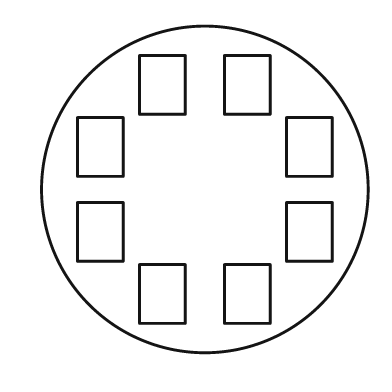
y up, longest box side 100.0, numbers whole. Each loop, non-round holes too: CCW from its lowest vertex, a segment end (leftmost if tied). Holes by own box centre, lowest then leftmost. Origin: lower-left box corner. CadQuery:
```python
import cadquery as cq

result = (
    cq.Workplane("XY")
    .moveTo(50.0, 50.0)
    .circle(50.0)
    .moveTo(30.0, 9.0)
    .lineTo(44.0, 9.0)
    .lineTo(44.0, 27.0)
    .lineTo(30.0, 27.0)
    .close()
    .moveTo(56.0, 9.0)
    .lineTo(70.0, 9.0)
    .lineTo(70.0, 27.0)
    .lineTo(56.0, 27.0)
    .close()
    .moveTo(11.0, 28.0)
    .lineTo(25.0, 28.0)
    .lineTo(25.0, 46.0)
    .lineTo(11.0, 46.0)
    .close()
    .moveTo(75.0, 28.0)
    .lineTo(89.0, 28.0)
    .lineTo(89.0, 46.0)
    .lineTo(75.0, 46.0)
    .close()
    .moveTo(11.0, 54.0)
    .lineTo(25.0, 54.0)
    .lineTo(25.0, 72.0)
    .lineTo(11.0, 72.0)
    .close()
    .moveTo(75.0, 54.0)
    .lineTo(89.0, 54.0)
    .lineTo(89.0, 72.0)
    .lineTo(75.0, 72.0)
    .close()
    .moveTo(30.0, 73.0)
    .lineTo(44.0, 73.0)
    .lineTo(44.0, 91.0)
    .lineTo(30.0, 91.0)
    .close()
    .moveTo(56.0, 73.0)
    .lineTo(70.0, 73.0)
    .lineTo(70.0, 91.0)
    .lineTo(56.0, 91.0)
    .close()
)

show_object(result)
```